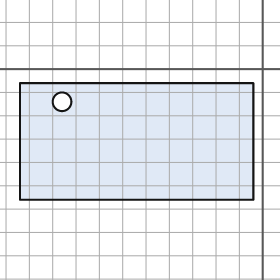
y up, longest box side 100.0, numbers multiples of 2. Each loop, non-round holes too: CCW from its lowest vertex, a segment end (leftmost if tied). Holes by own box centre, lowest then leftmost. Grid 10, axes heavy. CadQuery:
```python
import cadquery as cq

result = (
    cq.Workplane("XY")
    .moveTo(-104.0, -56.0)
    .lineTo(-4.0, -56.0)
    .lineTo(-4.0, -6.0)
    .lineTo(-104.0, -6.0)
    .close()
    .moveTo(-86.0, -14.0)
    .circle(4.0)
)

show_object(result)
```